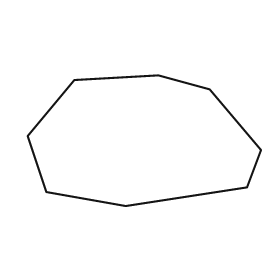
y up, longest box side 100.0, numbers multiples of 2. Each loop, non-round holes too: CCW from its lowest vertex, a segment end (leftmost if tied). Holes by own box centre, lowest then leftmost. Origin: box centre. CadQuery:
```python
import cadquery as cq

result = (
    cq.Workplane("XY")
    .moveTo(-8.0, -28.0)
    .lineTo(44.0, -20.0)
    .lineTo(50.0, -4.0)
    .lineTo(28.0, 22.0)
    .lineTo(6.0, 28.0)
    .lineTo(-30.0, 26.0)
    .lineTo(-50.0, 2.0)
    .lineTo(-42.0, -22.0)
    .close()
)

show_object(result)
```